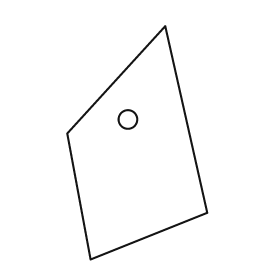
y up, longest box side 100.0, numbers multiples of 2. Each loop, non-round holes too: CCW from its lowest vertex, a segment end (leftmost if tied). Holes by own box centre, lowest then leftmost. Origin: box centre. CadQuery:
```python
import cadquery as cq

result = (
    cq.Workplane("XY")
    .moveTo(-20.0, -50.0)
    .lineTo(30.0, -30.0)
    .lineTo(12.0, 50.0)
    .lineTo(-30.0, 4.0)
    .close()
    .moveTo(-4.0, 10.0)
    .circle(4.0)
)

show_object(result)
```